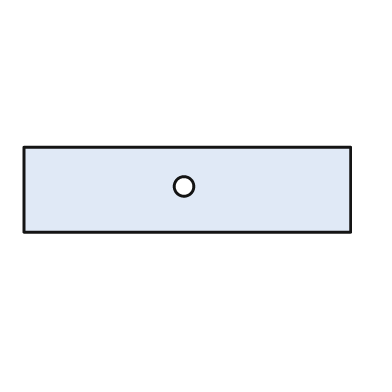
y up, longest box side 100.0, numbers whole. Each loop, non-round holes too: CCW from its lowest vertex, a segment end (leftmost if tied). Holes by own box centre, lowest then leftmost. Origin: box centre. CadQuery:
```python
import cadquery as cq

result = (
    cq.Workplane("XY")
    .moveTo(-50.0, -13.0)
    .lineTo(50.0, -13.0)
    .lineTo(50.0, 13.0)
    .lineTo(-50.0, 13.0)
    .close()
    .moveTo(-1.0, 1.0)
    .circle(3.0)
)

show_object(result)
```